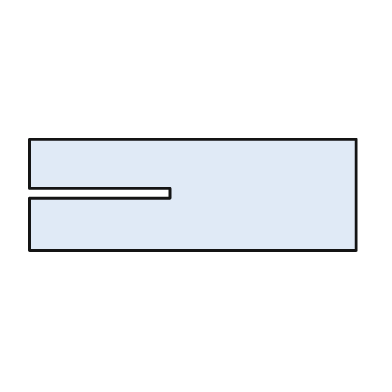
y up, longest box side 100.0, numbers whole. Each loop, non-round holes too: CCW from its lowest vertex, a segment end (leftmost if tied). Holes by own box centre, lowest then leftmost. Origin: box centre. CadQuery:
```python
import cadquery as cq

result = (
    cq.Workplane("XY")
    .moveTo(-50.0, -17.0)
    .lineTo(50.0, -17.0)
    .lineTo(50.0, 17.0)
    .lineTo(-50.0, 17.0)
    .lineTo(-50.0, 2.0)
    .lineTo(-7.0, 2.0)
    .lineTo(-7.0, -1.0)
    .lineTo(-50.0, -1.0)
    .close()
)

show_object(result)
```